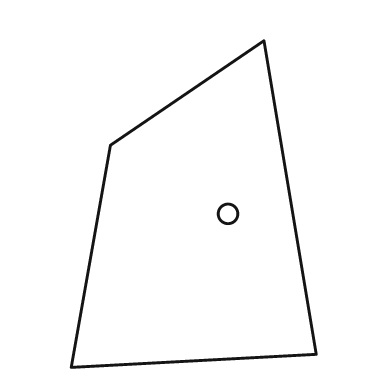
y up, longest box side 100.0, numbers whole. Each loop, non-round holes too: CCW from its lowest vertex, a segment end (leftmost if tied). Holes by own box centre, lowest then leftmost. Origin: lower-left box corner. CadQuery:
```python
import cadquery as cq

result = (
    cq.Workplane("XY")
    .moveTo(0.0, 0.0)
    .lineTo(75.0, 4.0)
    .lineTo(59.0, 100.0)
    .lineTo(12.0, 68.0)
    .close()
    .moveTo(48.0, 47.0)
    .circle(3.0)
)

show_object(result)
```